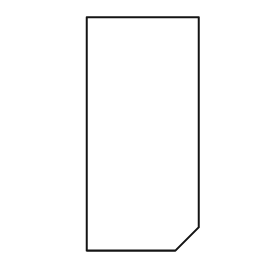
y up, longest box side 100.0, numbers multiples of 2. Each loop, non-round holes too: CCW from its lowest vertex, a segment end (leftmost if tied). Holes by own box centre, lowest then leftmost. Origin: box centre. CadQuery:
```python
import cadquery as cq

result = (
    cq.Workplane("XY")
    .moveTo(-24.0, -50.0)
    .lineTo(14.0, -50.0)
    .lineTo(24.0, -40.0)
    .lineTo(24.0, 50.0)
    .lineTo(-24.0, 50.0)
    .close()
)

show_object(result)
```